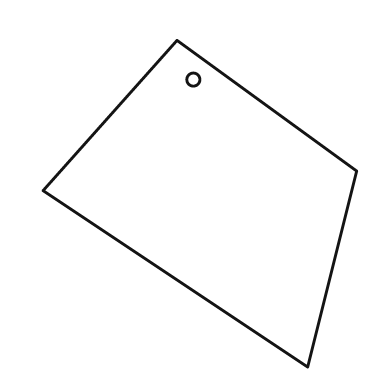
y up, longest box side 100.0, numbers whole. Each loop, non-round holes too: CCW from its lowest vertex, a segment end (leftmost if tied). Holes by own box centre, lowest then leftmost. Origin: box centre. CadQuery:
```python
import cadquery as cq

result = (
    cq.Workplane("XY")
    .moveTo(33.0, -50.0)
    .lineTo(48.0, 10.0)
    .lineTo(-7.0, 50.0)
    .lineTo(-48.0, 4.0)
    .close()
    .moveTo(-2.0, 38.0)
    .circle(2.0)
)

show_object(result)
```